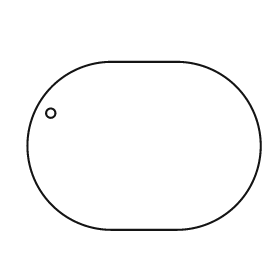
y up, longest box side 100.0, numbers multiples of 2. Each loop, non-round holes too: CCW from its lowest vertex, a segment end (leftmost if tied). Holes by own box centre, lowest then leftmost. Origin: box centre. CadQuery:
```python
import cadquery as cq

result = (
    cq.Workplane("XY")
    .moveTo(-14.0, -36.0)
    .lineTo(14.0, -36.0)
    .threePointArc((50.0, 0.0), (14.0, 36.0))
    .lineTo(-14.0, 36.0)
    .threePointArc((-50.0, 0.0), (-14.0, -36.0))
    .close()
    .moveTo(-40.0, 14.0)
    .circle(2.0)
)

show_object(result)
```